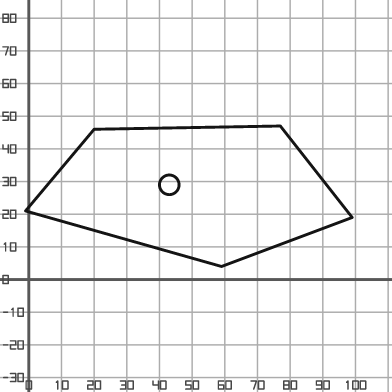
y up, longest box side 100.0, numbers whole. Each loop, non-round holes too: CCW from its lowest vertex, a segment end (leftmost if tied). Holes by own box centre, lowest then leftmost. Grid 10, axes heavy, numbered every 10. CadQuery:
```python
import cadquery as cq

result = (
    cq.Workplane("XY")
    .moveTo(59.0, 4.0)
    .lineTo(99.0, 19.0)
    .lineTo(77.0, 47.0)
    .lineTo(20.0, 46.0)
    .lineTo(-1.0, 21.0)
    .close()
    .moveTo(43.0, 29.0)
    .circle(3.0)
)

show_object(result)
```